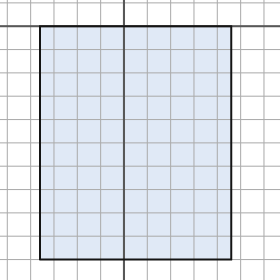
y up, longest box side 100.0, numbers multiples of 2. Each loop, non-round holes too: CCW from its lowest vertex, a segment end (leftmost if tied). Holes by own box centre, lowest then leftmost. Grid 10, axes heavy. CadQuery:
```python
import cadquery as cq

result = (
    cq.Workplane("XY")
    .moveTo(-36.0, -100.0)
    .lineTo(46.0, -100.0)
    .lineTo(46.0, 0.0)
    .lineTo(-36.0, 0.0)
    .close()
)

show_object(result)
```